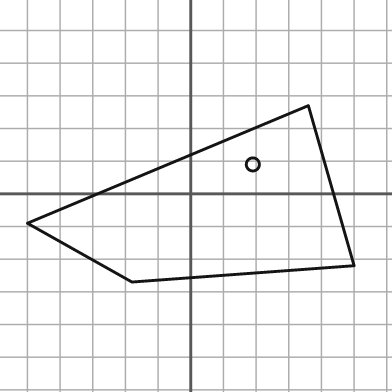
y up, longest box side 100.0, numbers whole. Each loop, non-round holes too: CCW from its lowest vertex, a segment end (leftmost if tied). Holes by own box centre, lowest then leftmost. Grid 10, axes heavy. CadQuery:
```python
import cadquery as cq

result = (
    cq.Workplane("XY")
    .moveTo(-18.0, -27.0)
    .lineTo(50.0, -22.0)
    .lineTo(36.0, 27.0)
    .lineTo(-50.0, -9.0)
    .close()
    .moveTo(19.0, 9.0)
    .circle(2.0)
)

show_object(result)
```